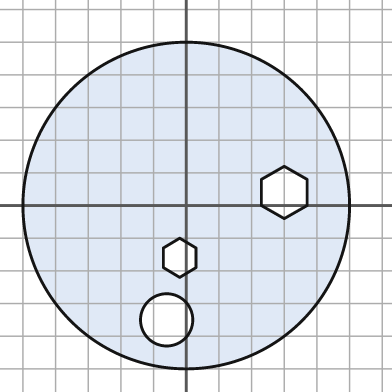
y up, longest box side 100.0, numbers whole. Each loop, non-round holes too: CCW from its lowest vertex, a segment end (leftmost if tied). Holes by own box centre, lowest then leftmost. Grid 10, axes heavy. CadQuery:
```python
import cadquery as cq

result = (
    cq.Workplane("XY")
    .moveTo(0.0, 0.0)
    .circle(50.0)
    .moveTo(-6.0, -35.0)
    .circle(8.0)
    .moveTo(-2.0, -22.0)
    .lineTo(3.0, -19.0)
    .lineTo(3.0, -13.0)
    .lineTo(-2.0, -10.0)
    .lineTo(-7.0, -13.0)
    .lineTo(-7.0, -19.0)
    .close()
    .moveTo(30.0, -4.0)
    .lineTo(37.0, 0.0)
    .lineTo(37.0, 8.0)
    .lineTo(30.0, 12.0)
    .lineTo(23.0, 8.0)
    .lineTo(23.0, 0.0)
    .close()
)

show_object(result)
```